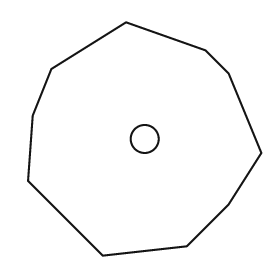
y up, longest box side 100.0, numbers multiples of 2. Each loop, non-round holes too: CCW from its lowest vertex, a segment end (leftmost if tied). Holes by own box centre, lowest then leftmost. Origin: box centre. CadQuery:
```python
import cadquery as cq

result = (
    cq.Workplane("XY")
    .moveTo(-18.0, -50.0)
    .lineTo(18.0, -46.0)
    .lineTo(36.0, -28.0)
    .lineTo(50.0, -6.0)
    .lineTo(36.0, 28.0)
    .lineTo(26.0, 38.0)
    .lineTo(-8.0, 50.0)
    .lineTo(-40.0, 30.0)
    .lineTo(-48.0, 10.0)
    .lineTo(-50.0, -18.0)
    .close()
    .moveTo(0.0, 0.0)
    .circle(6.0)
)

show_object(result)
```